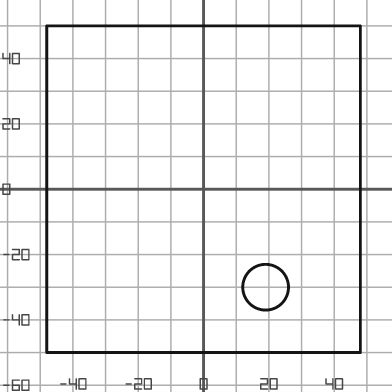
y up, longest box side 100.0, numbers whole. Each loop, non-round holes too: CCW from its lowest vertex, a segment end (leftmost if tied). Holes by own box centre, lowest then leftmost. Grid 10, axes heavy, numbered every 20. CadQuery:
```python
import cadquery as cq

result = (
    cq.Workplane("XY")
    .moveTo(-48.0, -50.0)
    .lineTo(48.0, -50.0)
    .lineTo(48.0, 50.0)
    .lineTo(-48.0, 50.0)
    .close()
    .moveTo(19.0, -30.0)
    .circle(7.0)
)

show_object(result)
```